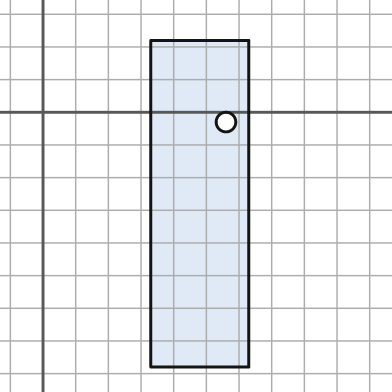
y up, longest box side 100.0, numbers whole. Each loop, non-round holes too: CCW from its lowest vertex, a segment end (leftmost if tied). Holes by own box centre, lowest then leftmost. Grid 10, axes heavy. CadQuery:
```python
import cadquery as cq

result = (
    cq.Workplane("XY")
    .moveTo(33.0, -78.0)
    .lineTo(63.0, -78.0)
    .lineTo(63.0, 22.0)
    .lineTo(33.0, 22.0)
    .close()
    .moveTo(56.0, -3.0)
    .circle(3.0)
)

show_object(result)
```